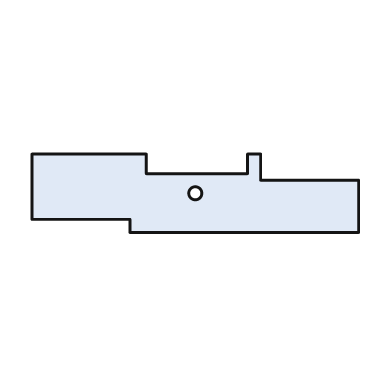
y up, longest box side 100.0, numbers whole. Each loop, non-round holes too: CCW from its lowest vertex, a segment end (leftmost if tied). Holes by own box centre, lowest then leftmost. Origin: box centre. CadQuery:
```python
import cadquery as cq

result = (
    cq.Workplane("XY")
    .moveTo(-20.0, -12.0)
    .lineTo(50.0, -12.0)
    .lineTo(50.0, 4.0)
    .lineTo(20.0, 4.0)
    .lineTo(20.0, 12.0)
    .lineTo(16.0, 12.0)
    .lineTo(16.0, 6.0)
    .lineTo(-15.0, 6.0)
    .lineTo(-15.0, 12.0)
    .lineTo(-50.0, 12.0)
    .lineTo(-50.0, -8.0)
    .lineTo(-20.0, -8.0)
    .close()
    .moveTo(0.0, 0.0)
    .circle(2.0)
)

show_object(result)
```